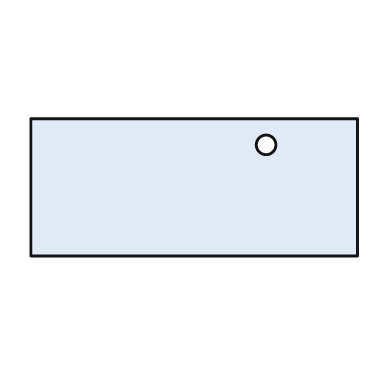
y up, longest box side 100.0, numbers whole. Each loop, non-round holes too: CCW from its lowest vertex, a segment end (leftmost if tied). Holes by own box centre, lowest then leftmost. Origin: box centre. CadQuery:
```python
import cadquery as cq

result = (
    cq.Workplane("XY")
    .moveTo(-50.0, -21.0)
    .lineTo(50.0, -21.0)
    .lineTo(50.0, 21.0)
    .lineTo(-50.0, 21.0)
    .close()
    .moveTo(22.0, 13.0)
    .circle(3.0)
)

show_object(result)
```